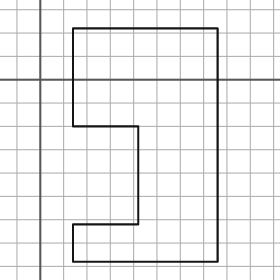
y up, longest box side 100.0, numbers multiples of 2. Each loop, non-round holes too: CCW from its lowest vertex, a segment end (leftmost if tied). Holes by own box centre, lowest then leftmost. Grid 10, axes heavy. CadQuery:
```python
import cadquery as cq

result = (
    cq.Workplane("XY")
    .moveTo(14.0, -78.0)
    .lineTo(76.0, -78.0)
    .lineTo(76.0, 22.0)
    .lineTo(14.0, 22.0)
    .lineTo(14.0, -20.0)
    .lineTo(42.0, -20.0)
    .lineTo(42.0, -62.0)
    .lineTo(14.0, -62.0)
    .close()
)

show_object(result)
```